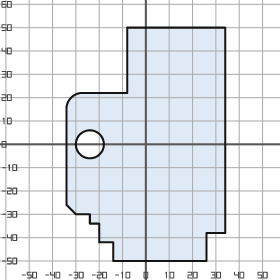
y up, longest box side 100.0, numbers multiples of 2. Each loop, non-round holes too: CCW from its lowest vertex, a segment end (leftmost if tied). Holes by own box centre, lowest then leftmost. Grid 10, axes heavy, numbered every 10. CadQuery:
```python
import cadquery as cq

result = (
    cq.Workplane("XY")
    .moveTo(-14.0, -50.0)
    .lineTo(26.0, -50.0)
    .lineTo(26.0, -38.0)
    .lineTo(34.0, -38.0)
    .lineTo(34.0, 50.0)
    .lineTo(-8.0, 50.0)
    .lineTo(-8.0, 22.0)
    .lineTo(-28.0, 22.0)
    .threePointArc((-32.0, 20.0), (-34.0, 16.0))
    .lineTo(-34.0, -26.0)
    .lineTo(-30.0, -30.0)
    .lineTo(-24.0, -30.0)
    .lineTo(-24.0, -34.0)
    .lineTo(-20.0, -34.0)
    .lineTo(-20.0, -42.0)
    .lineTo(-14.0, -42.0)
    .close()
    .moveTo(-24.0, 0.0)
    .circle(6.0)
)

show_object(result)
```